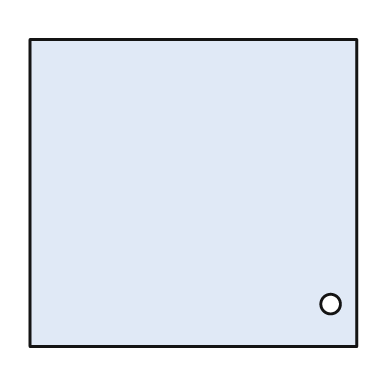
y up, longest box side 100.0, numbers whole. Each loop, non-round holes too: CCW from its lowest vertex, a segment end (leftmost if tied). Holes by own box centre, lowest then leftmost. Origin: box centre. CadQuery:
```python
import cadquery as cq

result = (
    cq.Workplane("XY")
    .moveTo(-50.0, -47.0)
    .lineTo(50.0, -47.0)
    .lineTo(50.0, 47.0)
    .lineTo(-50.0, 47.0)
    .close()
    .moveTo(42.0, -34.0)
    .circle(3.0)
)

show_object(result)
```